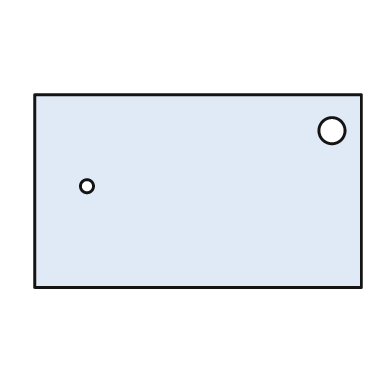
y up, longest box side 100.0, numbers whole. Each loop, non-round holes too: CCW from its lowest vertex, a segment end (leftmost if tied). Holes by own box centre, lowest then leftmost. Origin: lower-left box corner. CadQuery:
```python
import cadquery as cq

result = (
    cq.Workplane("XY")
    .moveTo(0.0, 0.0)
    .lineTo(100.0, 0.0)
    .lineTo(100.0, 59.0)
    .lineTo(0.0, 59.0)
    .close()
    .moveTo(16.0, 31.0)
    .circle(2.0)
    .moveTo(91.0, 48.0)
    .circle(4.0)
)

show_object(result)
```